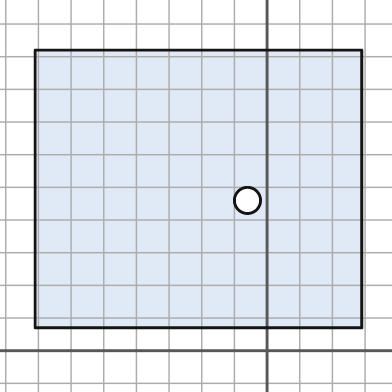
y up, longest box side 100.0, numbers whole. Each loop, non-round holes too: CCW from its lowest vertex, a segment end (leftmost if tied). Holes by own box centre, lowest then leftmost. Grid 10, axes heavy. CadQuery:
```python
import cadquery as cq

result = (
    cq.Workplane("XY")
    .moveTo(-71.0, 7.0)
    .lineTo(29.0, 7.0)
    .lineTo(29.0, 92.0)
    .lineTo(-71.0, 92.0)
    .close()
    .moveTo(-6.0, 46.0)
    .circle(4.0)
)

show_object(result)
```